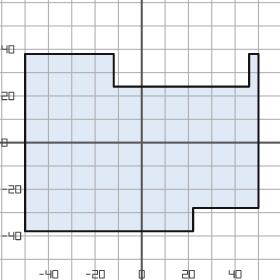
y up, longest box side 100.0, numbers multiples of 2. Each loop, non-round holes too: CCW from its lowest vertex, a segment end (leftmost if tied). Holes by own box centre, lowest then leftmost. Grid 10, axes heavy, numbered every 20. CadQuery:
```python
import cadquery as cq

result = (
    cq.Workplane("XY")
    .moveTo(-50.0, -38.0)
    .lineTo(22.0, -38.0)
    .lineTo(22.0, -28.0)
    .lineTo(50.0, -28.0)
    .lineTo(50.0, 38.0)
    .lineTo(46.0, 38.0)
    .lineTo(46.0, 24.0)
    .lineTo(-12.0, 24.0)
    .lineTo(-12.0, 38.0)
    .lineTo(-50.0, 38.0)
    .close()
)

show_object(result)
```